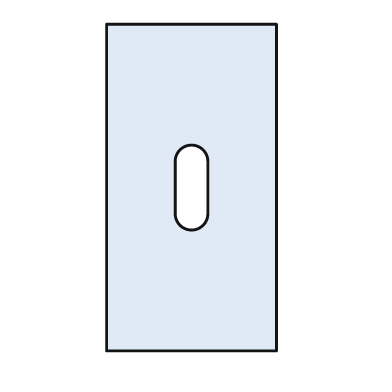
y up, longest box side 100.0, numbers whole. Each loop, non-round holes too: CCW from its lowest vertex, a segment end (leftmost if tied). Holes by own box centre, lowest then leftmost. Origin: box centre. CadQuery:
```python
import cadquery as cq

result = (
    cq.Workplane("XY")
    .moveTo(-26.0, -50.0)
    .lineTo(26.0, -50.0)
    .lineTo(26.0, 50.0)
    .lineTo(-26.0, 50.0)
    .close()
    .moveTo(-5.0, -8.0)
    .threePointArc((0.0, -13.0), (5.0, -8.0))
    .lineTo(5.0, 8.0)
    .threePointArc((0.0, 13.0), (-5.0, 8.0))
    .close()
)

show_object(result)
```